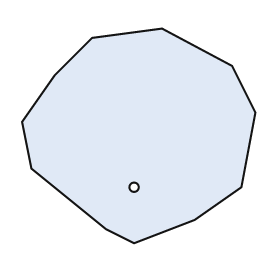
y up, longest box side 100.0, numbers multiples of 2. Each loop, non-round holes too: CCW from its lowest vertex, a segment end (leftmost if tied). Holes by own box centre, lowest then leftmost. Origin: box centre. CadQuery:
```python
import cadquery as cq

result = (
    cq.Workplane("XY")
    .moveTo(-2.0, -46.0)
    .lineTo(24.0, -36.0)
    .lineTo(44.0, -22.0)
    .lineTo(50.0, 10.0)
    .lineTo(40.0, 30.0)
    .lineTo(10.0, 46.0)
    .lineTo(-20.0, 42.0)
    .lineTo(-36.0, 26.0)
    .lineTo(-50.0, 6.0)
    .lineTo(-46.0, -14.0)
    .lineTo(-14.0, -40.0)
    .close()
    .moveTo(-2.0, -22.0)
    .circle(2.0)
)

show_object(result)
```